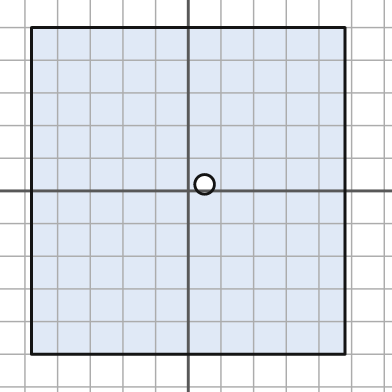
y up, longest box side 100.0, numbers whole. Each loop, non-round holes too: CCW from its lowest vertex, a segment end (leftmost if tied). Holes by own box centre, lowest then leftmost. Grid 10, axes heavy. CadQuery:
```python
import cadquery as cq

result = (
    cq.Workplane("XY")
    .moveTo(-48.0, -50.0)
    .lineTo(48.0, -50.0)
    .lineTo(48.0, 50.0)
    .lineTo(-48.0, 50.0)
    .close()
    .moveTo(5.0, 2.0)
    .circle(3.0)
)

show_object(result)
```